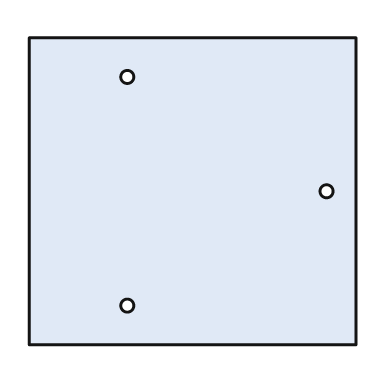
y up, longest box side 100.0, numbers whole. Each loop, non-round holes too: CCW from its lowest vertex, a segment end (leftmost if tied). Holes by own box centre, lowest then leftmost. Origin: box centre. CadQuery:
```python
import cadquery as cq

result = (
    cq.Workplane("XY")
    .moveTo(-50.0, -47.0)
    .lineTo(50.0, -47.0)
    .lineTo(50.0, 47.0)
    .lineTo(-50.0, 47.0)
    .close()
    .moveTo(-20.0, -35.0)
    .circle(2.0)
    .moveTo(41.0, 0.0)
    .circle(2.0)
    .moveTo(-20.0, 35.0)
    .circle(2.0)
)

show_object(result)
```